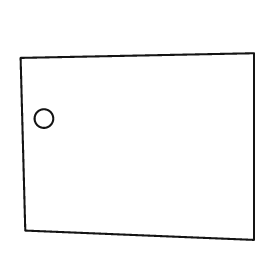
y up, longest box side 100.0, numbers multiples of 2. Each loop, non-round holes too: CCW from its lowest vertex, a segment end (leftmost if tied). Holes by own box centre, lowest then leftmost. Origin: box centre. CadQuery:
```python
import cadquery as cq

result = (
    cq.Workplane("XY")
    .moveTo(50.0, -40.0)
    .lineTo(50.0, 40.0)
    .lineTo(-50.0, 38.0)
    .lineTo(-48.0, -36.0)
    .close()
    .moveTo(-40.0, 12.0)
    .circle(4.0)
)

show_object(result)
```